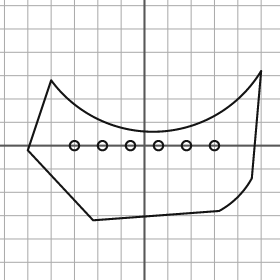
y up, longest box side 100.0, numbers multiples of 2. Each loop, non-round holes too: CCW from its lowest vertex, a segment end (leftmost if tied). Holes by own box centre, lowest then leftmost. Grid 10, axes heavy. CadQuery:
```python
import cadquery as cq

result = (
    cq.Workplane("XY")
    .moveTo(-22.0, -32.0)
    .lineTo(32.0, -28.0)
    .threePointArc((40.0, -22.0), (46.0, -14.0))
    .lineTo(50.0, 32.0)
    .threePointArc((6.0, 6.0), (-40.0, 28.0))
    .lineTo(-50.0, -2.0)
    .close()
    .moveTo(-30.0, 0.0)
    .circle(2.0)
    .moveTo(-18.0, 0.0)
    .circle(2.0)
    .moveTo(-6.0, 0.0)
    .circle(2.0)
    .moveTo(6.0, 0.0)
    .circle(2.0)
    .moveTo(18.0, 0.0)
    .circle(2.0)
    .moveTo(30.0, 0.0)
    .circle(2.0)
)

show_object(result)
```